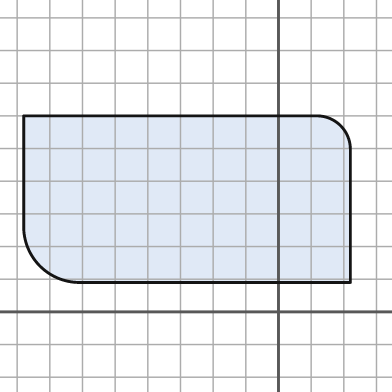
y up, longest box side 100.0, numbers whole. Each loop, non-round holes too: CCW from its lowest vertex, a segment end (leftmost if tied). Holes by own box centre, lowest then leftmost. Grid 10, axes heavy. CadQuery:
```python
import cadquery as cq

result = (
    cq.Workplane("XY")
    .moveTo(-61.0, 9.0)
    .lineTo(22.0, 9.0)
    .lineTo(22.0, 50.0)
    .threePointArc((19.0, 57.0), (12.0, 60.0))
    .lineTo(-78.0, 60.0)
    .lineTo(-78.0, 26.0)
    .threePointArc((-73.0, 14.0), (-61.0, 9.0))
    .close()
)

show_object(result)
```